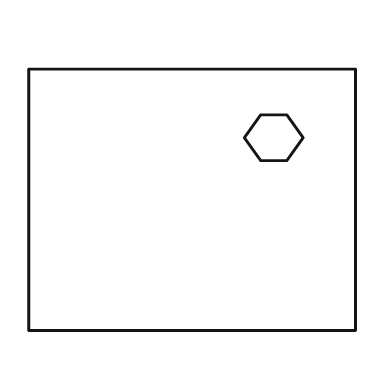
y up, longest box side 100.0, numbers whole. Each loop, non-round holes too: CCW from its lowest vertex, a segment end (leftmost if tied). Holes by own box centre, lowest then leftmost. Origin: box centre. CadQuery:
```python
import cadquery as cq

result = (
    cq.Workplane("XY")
    .moveTo(-50.0, -40.0)
    .lineTo(50.0, -40.0)
    .lineTo(50.0, 40.0)
    .lineTo(-50.0, 40.0)
    .close()
    .moveTo(21.0, 12.0)
    .lineTo(29.0, 12.0)
    .lineTo(34.0, 19.0)
    .lineTo(29.0, 26.0)
    .lineTo(21.0, 26.0)
    .lineTo(16.0, 19.0)
    .close()
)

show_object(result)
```